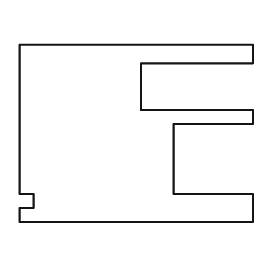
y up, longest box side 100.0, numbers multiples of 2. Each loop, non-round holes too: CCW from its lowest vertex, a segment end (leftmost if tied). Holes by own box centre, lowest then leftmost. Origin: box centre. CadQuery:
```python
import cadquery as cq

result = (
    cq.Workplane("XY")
    .moveTo(-50.0, -38.0)
    .lineTo(50.0, -38.0)
    .lineTo(50.0, -26.0)
    .lineTo(16.0, -26.0)
    .lineTo(16.0, 4.0)
    .lineTo(50.0, 4.0)
    .lineTo(50.0, 10.0)
    .lineTo(2.0, 10.0)
    .lineTo(2.0, 30.0)
    .lineTo(50.0, 30.0)
    .lineTo(50.0, 38.0)
    .lineTo(-50.0, 38.0)
    .lineTo(-50.0, -26.0)
    .lineTo(-44.0, -26.0)
    .lineTo(-44.0, -32.0)
    .lineTo(-50.0, -32.0)
    .close()
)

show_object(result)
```